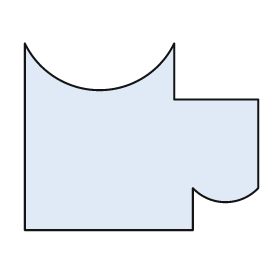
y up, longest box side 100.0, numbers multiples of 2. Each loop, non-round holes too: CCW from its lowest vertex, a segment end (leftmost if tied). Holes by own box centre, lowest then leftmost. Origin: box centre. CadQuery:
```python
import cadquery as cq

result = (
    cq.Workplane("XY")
    .moveTo(-50.0, -40.0)
    .lineTo(22.0, -40.0)
    .lineTo(22.0, -22.0)
    .threePointArc((36.0, -28.0), (50.0, -22.0))
    .lineTo(50.0, 16.0)
    .lineTo(14.0, 16.0)
    .lineTo(14.0, 40.0)
    .threePointArc((-18.0, 20.0), (-50.0, 40.0))
    .close()
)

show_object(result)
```